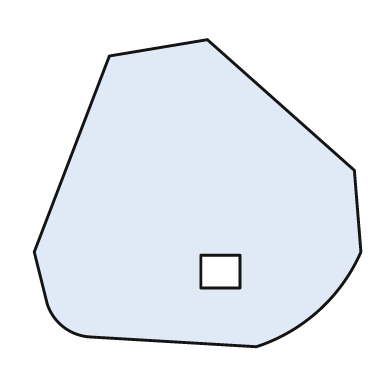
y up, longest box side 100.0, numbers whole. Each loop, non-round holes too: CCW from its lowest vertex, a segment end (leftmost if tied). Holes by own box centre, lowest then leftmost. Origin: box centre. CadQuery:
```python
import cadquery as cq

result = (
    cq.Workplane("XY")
    .moveTo(18.0, -47.0)
    .threePointArc((37.0, -36.0), (50.0, -18.0))
    .lineTo(48.0, 7.0)
    .lineTo(3.0, 47.0)
    .lineTo(-27.0, 42.0)
    .lineTo(-50.0, -18.0)
    .lineTo(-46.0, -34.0)
    .threePointArc((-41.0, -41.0), (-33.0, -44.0))
    .close()
    .moveTo(1.0, -29.0)
    .lineTo(13.0, -29.0)
    .lineTo(13.0, -19.0)
    .lineTo(1.0, -19.0)
    .close()
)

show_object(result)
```